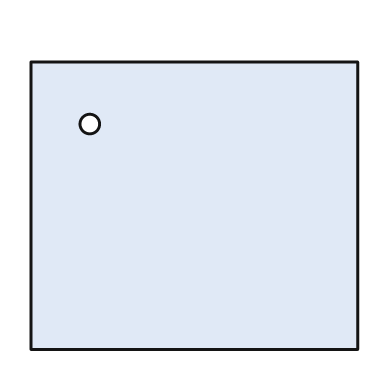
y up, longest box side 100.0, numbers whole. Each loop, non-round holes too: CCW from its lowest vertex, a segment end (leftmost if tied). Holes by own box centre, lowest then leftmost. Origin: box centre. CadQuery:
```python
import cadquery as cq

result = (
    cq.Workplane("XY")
    .moveTo(-50.0, -44.0)
    .lineTo(50.0, -44.0)
    .lineTo(50.0, 44.0)
    .lineTo(-50.0, 44.0)
    .close()
    .moveTo(-32.0, 25.0)
    .circle(3.0)
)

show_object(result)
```